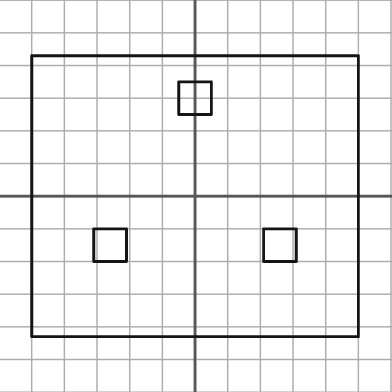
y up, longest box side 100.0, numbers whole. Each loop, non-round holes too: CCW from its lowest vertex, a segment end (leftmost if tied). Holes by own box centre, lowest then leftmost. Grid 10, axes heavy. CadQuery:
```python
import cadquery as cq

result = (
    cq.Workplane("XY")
    .moveTo(-50.0, -43.0)
    .lineTo(50.0, -43.0)
    .lineTo(50.0, 43.0)
    .lineTo(-50.0, 43.0)
    .close()
    .moveTo(-31.0, -20.0)
    .lineTo(-21.0, -20.0)
    .lineTo(-21.0, -10.0)
    .lineTo(-31.0, -10.0)
    .close()
    .moveTo(21.0, -20.0)
    .lineTo(31.0, -20.0)
    .lineTo(31.0, -10.0)
    .lineTo(21.0, -10.0)
    .close()
    .moveTo(-5.0, 25.0)
    .lineTo(5.0, 25.0)
    .lineTo(5.0, 35.0)
    .lineTo(-5.0, 35.0)
    .close()
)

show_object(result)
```